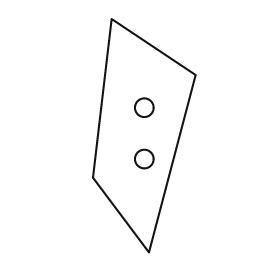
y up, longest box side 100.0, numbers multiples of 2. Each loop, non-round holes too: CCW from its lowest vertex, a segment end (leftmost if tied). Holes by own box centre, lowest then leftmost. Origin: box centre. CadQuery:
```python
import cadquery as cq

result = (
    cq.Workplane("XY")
    .moveTo(2.0, -50.0)
    .lineTo(22.0, 26.0)
    .lineTo(-14.0, 50.0)
    .lineTo(-22.0, -18.0)
    .close()
    .moveTo(0.0, -10.0)
    .circle(4.0)
    .moveTo(0.0, 12.0)
    .circle(4.0)
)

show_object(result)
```